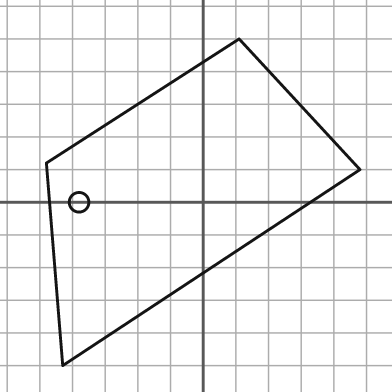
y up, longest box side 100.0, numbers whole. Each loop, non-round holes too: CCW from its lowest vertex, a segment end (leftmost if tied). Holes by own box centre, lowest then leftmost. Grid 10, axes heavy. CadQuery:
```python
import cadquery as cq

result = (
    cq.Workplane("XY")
    .moveTo(-43.0, -50.0)
    .lineTo(48.0, 10.0)
    .lineTo(11.0, 50.0)
    .lineTo(-48.0, 12.0)
    .close()
    .moveTo(-38.0, 0.0)
    .circle(3.0)
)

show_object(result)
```